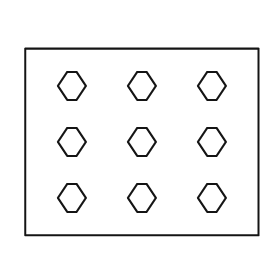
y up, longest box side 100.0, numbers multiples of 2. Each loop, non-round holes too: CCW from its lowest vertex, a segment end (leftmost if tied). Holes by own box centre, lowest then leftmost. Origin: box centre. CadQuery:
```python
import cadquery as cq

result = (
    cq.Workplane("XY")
    .moveTo(-50.0, -40.0)
    .lineTo(50.0, -40.0)
    .lineTo(50.0, 40.0)
    .lineTo(-50.0, 40.0)
    .close()
    .moveTo(-32.0, -30.0)
    .lineTo(-28.0, -30.0)
    .lineTo(-24.0, -24.0)
    .lineTo(-28.0, -18.0)
    .lineTo(-32.0, -18.0)
    .lineTo(-36.0, -24.0)
    .close()
    .moveTo(-2.0, -30.0)
    .lineTo(2.0, -30.0)
    .lineTo(6.0, -24.0)
    .lineTo(2.0, -18.0)
    .lineTo(-2.0, -18.0)
    .lineTo(-6.0, -24.0)
    .close()
    .moveTo(28.0, -30.0)
    .lineTo(32.0, -30.0)
    .lineTo(36.0, -24.0)
    .lineTo(32.0, -18.0)
    .lineTo(28.0, -18.0)
    .lineTo(24.0, -24.0)
    .close()
    .moveTo(-32.0, -6.0)
    .lineTo(-28.0, -6.0)
    .lineTo(-24.0, 0.0)
    .lineTo(-28.0, 6.0)
    .lineTo(-32.0, 6.0)
    .lineTo(-36.0, 0.0)
    .close()
    .moveTo(-2.0, -6.0)
    .lineTo(2.0, -6.0)
    .lineTo(6.0, 0.0)
    .lineTo(2.0, 6.0)
    .lineTo(-2.0, 6.0)
    .lineTo(-6.0, 0.0)
    .close()
    .moveTo(28.0, -6.0)
    .lineTo(32.0, -6.0)
    .lineTo(36.0, 0.0)
    .lineTo(32.0, 6.0)
    .lineTo(28.0, 6.0)
    .lineTo(24.0, 0.0)
    .close()
    .moveTo(-32.0, 18.0)
    .lineTo(-28.0, 18.0)
    .lineTo(-24.0, 24.0)
    .lineTo(-28.0, 30.0)
    .lineTo(-32.0, 30.0)
    .lineTo(-36.0, 24.0)
    .close()
    .moveTo(-2.0, 18.0)
    .lineTo(2.0, 18.0)
    .lineTo(6.0, 24.0)
    .lineTo(2.0, 30.0)
    .lineTo(-2.0, 30.0)
    .lineTo(-6.0, 24.0)
    .close()
    .moveTo(28.0, 18.0)
    .lineTo(32.0, 18.0)
    .lineTo(36.0, 24.0)
    .lineTo(32.0, 30.0)
    .lineTo(28.0, 30.0)
    .lineTo(24.0, 24.0)
    .close()
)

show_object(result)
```